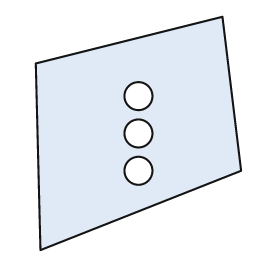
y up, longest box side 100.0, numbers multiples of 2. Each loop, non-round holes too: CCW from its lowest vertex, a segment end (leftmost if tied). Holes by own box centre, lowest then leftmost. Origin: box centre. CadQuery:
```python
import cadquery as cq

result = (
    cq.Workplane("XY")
    .moveTo(-42.0, -50.0)
    .lineTo(44.0, -16.0)
    .lineTo(36.0, 50.0)
    .lineTo(-44.0, 30.0)
    .close()
    .moveTo(0.0, -16.0)
    .circle(6.0)
    .moveTo(0.0, 0.0)
    .circle(6.0)
    .moveTo(0.0, 16.0)
    .circle(6.0)
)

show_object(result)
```